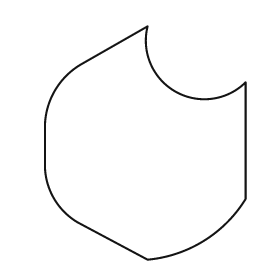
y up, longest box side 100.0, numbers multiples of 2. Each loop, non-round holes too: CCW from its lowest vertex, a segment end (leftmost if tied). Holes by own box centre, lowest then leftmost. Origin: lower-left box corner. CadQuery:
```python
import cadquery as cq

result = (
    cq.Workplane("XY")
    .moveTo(44.0, 0.0)
    .threePointArc((68.0, 8.0), (86.0, 26.0))
    .lineTo(86.0, 76.0)
    .threePointArc((56.0, 72.0), (44.0, 100.0))
    .lineTo(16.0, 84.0)
    .threePointArc((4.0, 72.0), (0.0, 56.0))
    .lineTo(0.0, 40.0)
    .threePointArc((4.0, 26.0), (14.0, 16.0))
    .close()
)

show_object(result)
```